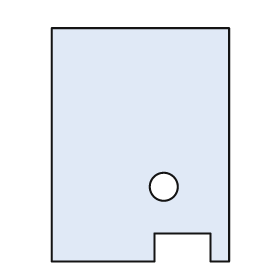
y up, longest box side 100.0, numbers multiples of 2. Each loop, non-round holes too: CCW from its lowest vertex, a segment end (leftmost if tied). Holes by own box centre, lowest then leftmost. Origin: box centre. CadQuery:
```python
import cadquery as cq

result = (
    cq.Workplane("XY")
    .moveTo(-38.0, -50.0)
    .lineTo(6.0, -50.0)
    .lineTo(6.0, -38.0)
    .lineTo(30.0, -38.0)
    .lineTo(30.0, -50.0)
    .lineTo(38.0, -50.0)
    .lineTo(38.0, 50.0)
    .lineTo(-38.0, 50.0)
    .close()
    .moveTo(10.0, -18.0)
    .circle(6.0)
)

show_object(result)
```